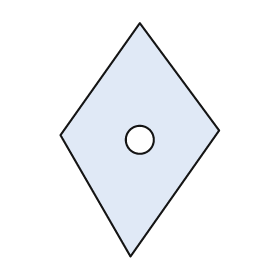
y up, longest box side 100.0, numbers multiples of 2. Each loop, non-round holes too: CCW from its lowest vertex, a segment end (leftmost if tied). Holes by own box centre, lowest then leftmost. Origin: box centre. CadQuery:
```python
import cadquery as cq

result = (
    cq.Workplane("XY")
    .moveTo(-4.0, -50.0)
    .lineTo(34.0, 4.0)
    .lineTo(0.0, 50.0)
    .lineTo(-34.0, 2.0)
    .close()
    .moveTo(0.0, 0.0)
    .circle(6.0)
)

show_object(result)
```